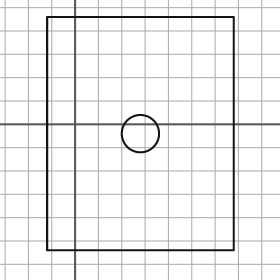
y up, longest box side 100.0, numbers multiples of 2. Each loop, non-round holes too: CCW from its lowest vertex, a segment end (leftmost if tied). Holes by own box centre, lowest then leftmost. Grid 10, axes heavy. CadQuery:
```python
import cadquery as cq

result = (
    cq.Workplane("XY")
    .moveTo(-12.0, -54.0)
    .lineTo(68.0, -54.0)
    .lineTo(68.0, 46.0)
    .lineTo(-12.0, 46.0)
    .close()
    .moveTo(28.0, -4.0)
    .circle(8.0)
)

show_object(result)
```